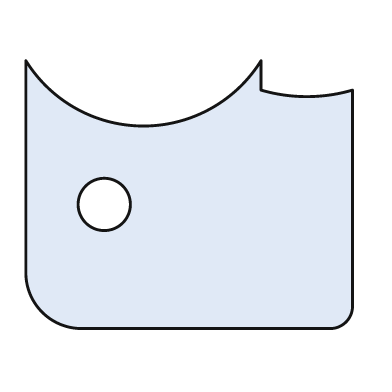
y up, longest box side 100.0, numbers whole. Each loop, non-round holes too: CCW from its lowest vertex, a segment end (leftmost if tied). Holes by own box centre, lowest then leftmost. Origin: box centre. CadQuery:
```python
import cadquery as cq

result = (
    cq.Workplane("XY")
    .moveTo(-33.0, -41.0)
    .lineTo(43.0, -41.0)
    .threePointArc((48.0, -39.0), (50.0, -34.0))
    .lineTo(50.0, 32.0)
    .threePointArc((36.0, 30.0), (22.0, 32.0))
    .lineTo(22.0, 41.0)
    .threePointArc((-14.0, 21.0), (-50.0, 41.0))
    .lineTo(-50.0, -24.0)
    .threePointArc((-45.0, -36.0), (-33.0, -41.0))
    .close()
    .moveTo(-26.0, -3.0)
    .circle(8.0)
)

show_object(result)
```